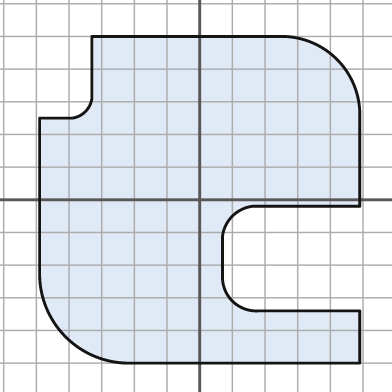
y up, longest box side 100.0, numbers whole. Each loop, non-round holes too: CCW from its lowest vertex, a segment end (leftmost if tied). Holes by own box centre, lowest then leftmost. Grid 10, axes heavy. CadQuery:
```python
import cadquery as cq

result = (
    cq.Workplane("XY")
    .moveTo(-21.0, -50.0)
    .lineTo(49.0, -50.0)
    .lineTo(49.0, -34.0)
    .lineTo(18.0, -34.0)
    .threePointArc((10.0, -31.0), (7.0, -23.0))
    .lineTo(7.0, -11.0)
    .threePointArc((10.0, -5.0), (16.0, -2.0))
    .lineTo(49.0, -2.0)
    .lineTo(49.0, 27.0)
    .threePointArc((42.0, 43.0), (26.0, 50.0))
    .lineTo(-33.0, 50.0)
    .lineTo(-33.0, 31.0)
    .threePointArc((-35.0, 27.0), (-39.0, 25.0))
    .lineTo(-49.0, 25.0)
    .lineTo(-49.0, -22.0)
    .threePointArc((-41.0, -42.0), (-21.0, -50.0))
    .close()
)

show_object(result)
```